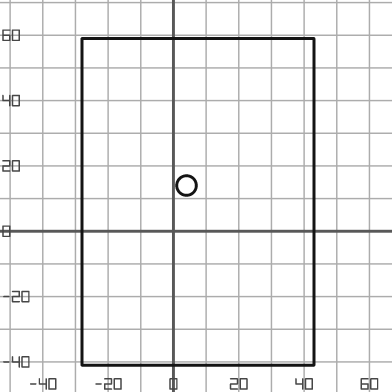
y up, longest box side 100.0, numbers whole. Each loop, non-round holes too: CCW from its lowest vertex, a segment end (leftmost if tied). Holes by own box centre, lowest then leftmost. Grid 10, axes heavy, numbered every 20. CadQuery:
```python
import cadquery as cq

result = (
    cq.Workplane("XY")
    .moveTo(-28.0, -41.0)
    .lineTo(43.0, -41.0)
    .lineTo(43.0, 59.0)
    .lineTo(-28.0, 59.0)
    .close()
    .moveTo(4.0, 14.0)
    .circle(3.0)
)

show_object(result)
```